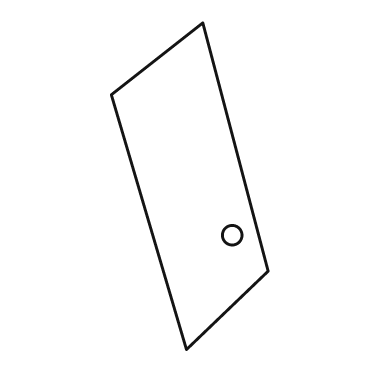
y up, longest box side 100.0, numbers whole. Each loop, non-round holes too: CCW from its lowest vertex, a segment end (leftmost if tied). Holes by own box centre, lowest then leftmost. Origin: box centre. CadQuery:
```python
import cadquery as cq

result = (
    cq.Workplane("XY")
    .moveTo(-1.0, -50.0)
    .lineTo(24.0, -26.0)
    .lineTo(4.0, 50.0)
    .lineTo(-24.0, 28.0)
    .close()
    .moveTo(13.0, -15.0)
    .circle(3.0)
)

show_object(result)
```